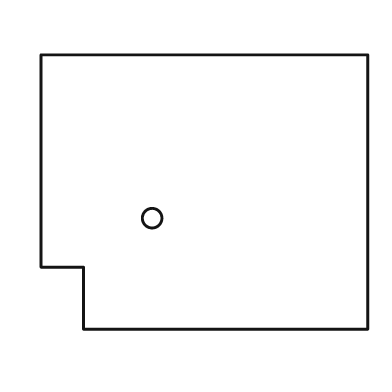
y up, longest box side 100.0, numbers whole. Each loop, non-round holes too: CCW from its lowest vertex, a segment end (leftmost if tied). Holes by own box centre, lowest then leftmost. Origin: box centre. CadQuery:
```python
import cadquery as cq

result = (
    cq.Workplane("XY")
    .moveTo(-37.0, -42.0)
    .lineTo(50.0, -42.0)
    .lineTo(50.0, 42.0)
    .lineTo(-50.0, 42.0)
    .lineTo(-50.0, -23.0)
    .lineTo(-37.0, -23.0)
    .close()
    .moveTo(-16.0, -8.0)
    .circle(3.0)
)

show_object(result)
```